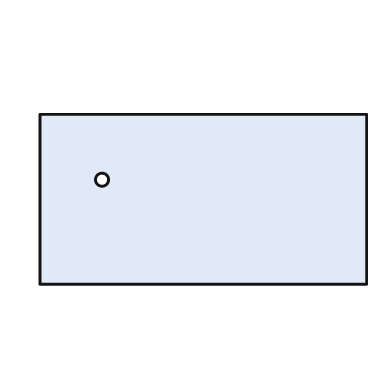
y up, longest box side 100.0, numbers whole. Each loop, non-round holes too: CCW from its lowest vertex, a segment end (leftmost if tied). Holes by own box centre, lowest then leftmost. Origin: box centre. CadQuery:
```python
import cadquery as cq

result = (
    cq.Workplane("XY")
    .moveTo(-50.0, -26.0)
    .lineTo(50.0, -26.0)
    .lineTo(50.0, 26.0)
    .lineTo(-50.0, 26.0)
    .close()
    .moveTo(-31.0, 6.0)
    .circle(2.0)
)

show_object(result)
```